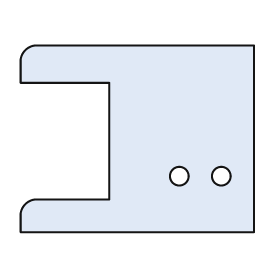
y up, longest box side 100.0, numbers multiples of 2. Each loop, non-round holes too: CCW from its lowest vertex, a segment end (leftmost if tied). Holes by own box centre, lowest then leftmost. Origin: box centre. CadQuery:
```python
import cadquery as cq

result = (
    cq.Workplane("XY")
    .moveTo(-50.0, -40.0)
    .lineTo(50.0, -40.0)
    .lineTo(50.0, 40.0)
    .lineTo(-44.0, 40.0)
    .threePointArc((-48.0, 38.0), (-50.0, 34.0))
    .lineTo(-50.0, 24.0)
    .lineTo(-12.0, 24.0)
    .lineTo(-12.0, -26.0)
    .lineTo(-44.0, -26.0)
    .threePointArc((-48.0, -28.0), (-50.0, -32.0))
    .close()
    .moveTo(18.0, -16.0)
    .circle(4.0)
    .moveTo(36.0, -16.0)
    .circle(4.0)
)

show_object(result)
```